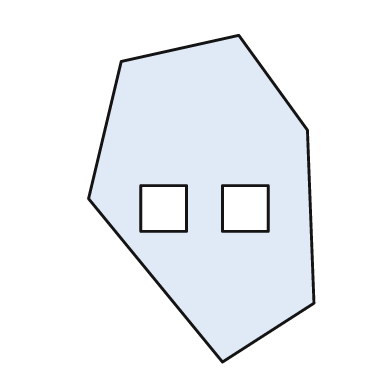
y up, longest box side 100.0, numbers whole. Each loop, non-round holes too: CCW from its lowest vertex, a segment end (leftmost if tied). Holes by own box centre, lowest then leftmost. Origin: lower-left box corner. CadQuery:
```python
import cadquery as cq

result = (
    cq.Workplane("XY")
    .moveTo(41.0, 0.0)
    .lineTo(69.0, 18.0)
    .lineTo(67.0, 71.0)
    .lineTo(46.0, 100.0)
    .lineTo(10.0, 92.0)
    .lineTo(0.0, 50.0)
    .close()
    .moveTo(16.0, 40.0)
    .lineTo(30.0, 40.0)
    .lineTo(30.0, 54.0)
    .lineTo(16.0, 54.0)
    .close()
    .moveTo(41.0, 40.0)
    .lineTo(55.0, 40.0)
    .lineTo(55.0, 54.0)
    .lineTo(41.0, 54.0)
    .close()
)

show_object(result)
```